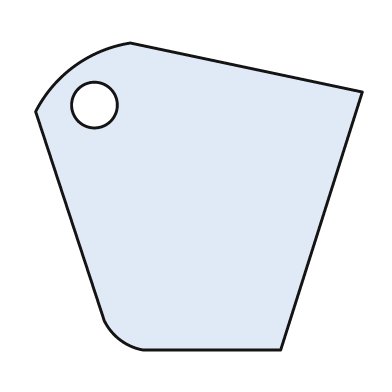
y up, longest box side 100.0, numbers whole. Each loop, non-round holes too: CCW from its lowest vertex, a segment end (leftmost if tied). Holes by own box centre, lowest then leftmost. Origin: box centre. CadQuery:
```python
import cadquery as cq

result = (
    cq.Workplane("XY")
    .moveTo(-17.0, -47.0)
    .lineTo(25.0, -47.0)
    .lineTo(50.0, 32.0)
    .lineTo(-21.0, 47.0)
    .threePointArc((-38.0, 40.0), (-50.0, 26.0))
    .lineTo(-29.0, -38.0)
    .threePointArc((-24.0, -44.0), (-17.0, -47.0))
    .close()
    .moveTo(-32.0, 28.0)
    .circle(7.0)
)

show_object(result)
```